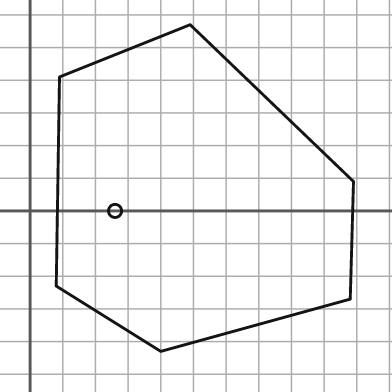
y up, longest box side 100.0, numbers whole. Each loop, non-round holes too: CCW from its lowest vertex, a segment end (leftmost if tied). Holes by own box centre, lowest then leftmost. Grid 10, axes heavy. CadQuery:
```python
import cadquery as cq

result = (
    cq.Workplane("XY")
    .moveTo(40.0, -43.0)
    .lineTo(98.0, -27.0)
    .lineTo(99.0, 9.0)
    .lineTo(49.0, 57.0)
    .lineTo(9.0, 41.0)
    .lineTo(8.0, -23.0)
    .close()
    .moveTo(26.0, 0.0)
    .circle(2.0)
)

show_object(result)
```